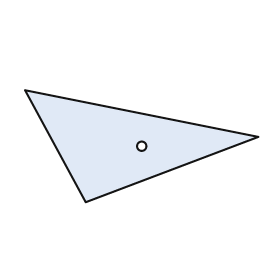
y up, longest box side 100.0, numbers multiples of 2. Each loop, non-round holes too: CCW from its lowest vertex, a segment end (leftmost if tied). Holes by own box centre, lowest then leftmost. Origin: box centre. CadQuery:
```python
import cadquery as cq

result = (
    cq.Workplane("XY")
    .moveTo(-24.0, -24.0)
    .lineTo(50.0, 4.0)
    .lineTo(-50.0, 24.0)
    .close()
    .moveTo(0.0, 0.0)
    .circle(2.0)
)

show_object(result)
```